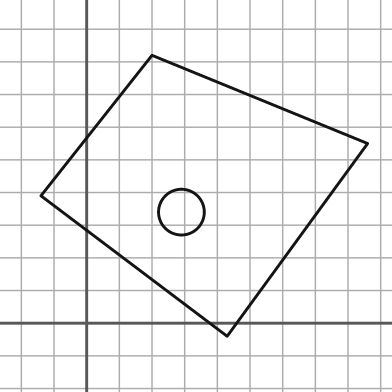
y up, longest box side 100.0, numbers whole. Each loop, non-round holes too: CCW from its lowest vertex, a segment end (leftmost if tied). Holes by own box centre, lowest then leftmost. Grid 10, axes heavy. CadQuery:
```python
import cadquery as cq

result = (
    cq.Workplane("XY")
    .moveTo(43.0, -4.0)
    .lineTo(86.0, 55.0)
    .lineTo(20.0, 82.0)
    .lineTo(-14.0, 39.0)
    .close()
    .moveTo(29.0, 34.0)
    .circle(7.0)
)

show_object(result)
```